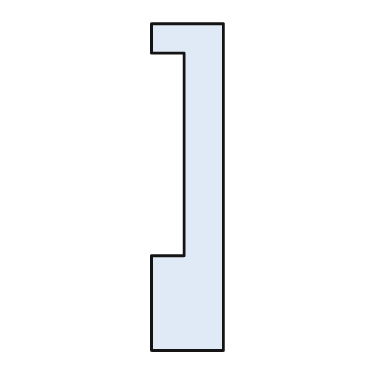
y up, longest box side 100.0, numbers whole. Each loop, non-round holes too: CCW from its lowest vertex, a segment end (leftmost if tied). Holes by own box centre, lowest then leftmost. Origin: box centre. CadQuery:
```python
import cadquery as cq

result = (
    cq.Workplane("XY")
    .moveTo(-11.0, -50.0)
    .lineTo(11.0, -50.0)
    .lineTo(11.0, 50.0)
    .lineTo(-11.0, 50.0)
    .lineTo(-11.0, 41.0)
    .lineTo(-1.0, 41.0)
    .lineTo(-1.0, -21.0)
    .lineTo(-11.0, -21.0)
    .close()
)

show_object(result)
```